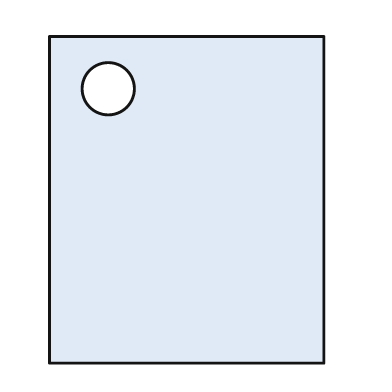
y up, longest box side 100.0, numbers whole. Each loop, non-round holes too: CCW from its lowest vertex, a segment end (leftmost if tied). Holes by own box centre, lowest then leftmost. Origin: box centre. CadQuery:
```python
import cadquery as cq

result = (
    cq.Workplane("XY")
    .moveTo(-42.0, -50.0)
    .lineTo(42.0, -50.0)
    .lineTo(42.0, 50.0)
    .lineTo(-42.0, 50.0)
    .close()
    .moveTo(-24.0, 34.0)
    .circle(8.0)
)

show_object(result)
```